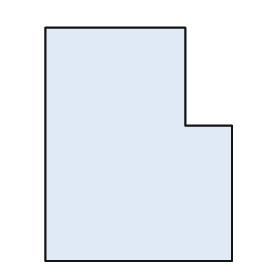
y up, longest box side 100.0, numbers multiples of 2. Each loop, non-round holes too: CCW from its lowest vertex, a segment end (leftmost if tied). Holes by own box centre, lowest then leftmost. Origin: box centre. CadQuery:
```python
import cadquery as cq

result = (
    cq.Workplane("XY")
    .moveTo(-40.0, -50.0)
    .lineTo(40.0, -50.0)
    .lineTo(40.0, 8.0)
    .lineTo(20.0, 8.0)
    .lineTo(20.0, 50.0)
    .lineTo(-40.0, 50.0)
    .close()
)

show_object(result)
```